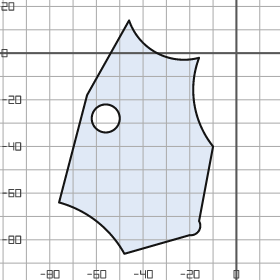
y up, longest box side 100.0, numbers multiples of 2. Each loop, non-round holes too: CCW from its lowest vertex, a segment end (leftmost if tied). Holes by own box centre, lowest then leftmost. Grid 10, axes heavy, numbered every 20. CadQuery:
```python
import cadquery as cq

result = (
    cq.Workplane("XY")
    .moveTo(-48.0, -86.0)
    .lineTo(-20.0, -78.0)
    .threePointArc((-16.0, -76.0), (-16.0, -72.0))
    .lineTo(-10.0, -40.0)
    .threePointArc((-18.0, -22.0), (-16.0, -2.0))
    .threePointArc((-34.0, 0.0), (-46.0, 14.0))
    .lineTo(-64.0, -18.0)
    .lineTo(-76.0, -64.0)
    .threePointArc((-60.0, -72.0), (-48.0, -86.0))
    .close()
    .moveTo(-56.0, -28.0)
    .circle(6.0)
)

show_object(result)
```